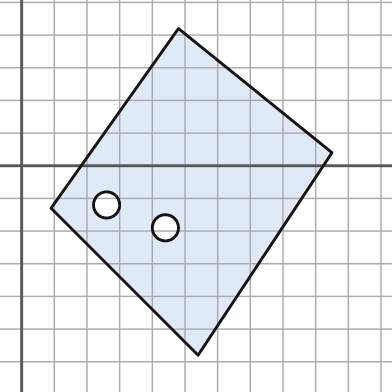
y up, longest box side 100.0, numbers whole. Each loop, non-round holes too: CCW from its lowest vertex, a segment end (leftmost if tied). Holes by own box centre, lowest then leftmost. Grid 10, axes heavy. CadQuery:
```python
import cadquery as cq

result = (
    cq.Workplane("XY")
    .moveTo(54.0, -58.0)
    .lineTo(95.0, 4.0)
    .lineTo(48.0, 42.0)
    .lineTo(9.0, -13.0)
    .close()
    .moveTo(44.0, -19.0)
    .circle(4.0)
    .moveTo(26.0, -12.0)
    .circle(4.0)
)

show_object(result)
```